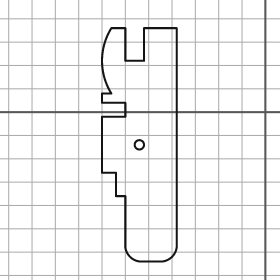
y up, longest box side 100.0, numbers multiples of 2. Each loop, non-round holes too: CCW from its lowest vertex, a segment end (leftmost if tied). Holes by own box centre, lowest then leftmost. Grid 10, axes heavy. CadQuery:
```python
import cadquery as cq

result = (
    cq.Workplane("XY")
    .moveTo(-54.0, -64.0)
    .lineTo(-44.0, -64.0)
    .threePointArc((-40.0, -62.0), (-38.0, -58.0))
    .lineTo(-38.0, 36.0)
    .lineTo(-52.0, 36.0)
    .lineTo(-52.0, 22.0)
    .lineTo(-60.0, 22.0)
    .lineTo(-60.0, 36.0)
    .lineTo(-66.0, 36.0)
    .threePointArc((-70.0, 22.0), (-66.0, 8.0))
    .lineTo(-70.0, 8.0)
    .lineTo(-70.0, 4.0)
    .lineTo(-60.0, 4.0)
    .lineTo(-60.0, -2.0)
    .lineTo(-70.0, -2.0)
    .lineTo(-70.0, -26.0)
    .lineTo(-64.0, -26.0)
    .lineTo(-64.0, -36.0)
    .lineTo(-60.0, -36.0)
    .lineTo(-60.0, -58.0)
    .threePointArc((-58.0, -62.0), (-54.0, -64.0))
    .close()
    .moveTo(-54.0, -14.0)
    .circle(2.0)
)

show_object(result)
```